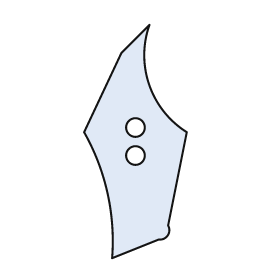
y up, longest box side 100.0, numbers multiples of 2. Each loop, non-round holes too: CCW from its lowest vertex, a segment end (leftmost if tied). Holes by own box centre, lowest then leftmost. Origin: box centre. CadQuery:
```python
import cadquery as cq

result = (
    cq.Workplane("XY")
    .moveTo(-10.0, -50.0)
    .lineTo(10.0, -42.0)
    .threePointArc((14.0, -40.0), (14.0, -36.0))
    .lineTo(22.0, 4.0)
    .threePointArc((6.0, 24.0), (6.0, 50.0))
    .lineTo(-6.0, 38.0)
    .lineTo(-22.0, 4.0)
    .threePointArc((-12.0, -22.0), (-10.0, -50.0))
    .close()
    .moveTo(0.0, -6.0)
    .circle(4.0)
    .moveTo(0.0, 6.0)
    .circle(4.0)
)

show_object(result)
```